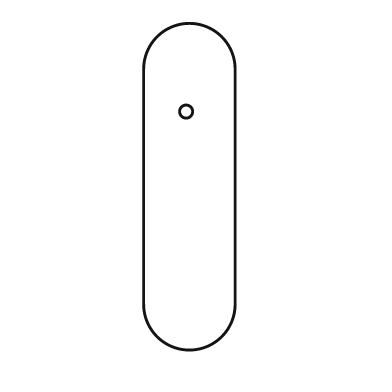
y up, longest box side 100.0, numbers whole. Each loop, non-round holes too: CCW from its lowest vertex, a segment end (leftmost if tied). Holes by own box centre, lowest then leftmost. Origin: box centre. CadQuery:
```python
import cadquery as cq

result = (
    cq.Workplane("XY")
    .moveTo(-14.0, -36.0)
    .threePointArc((0.0, -50.0), (14.0, -36.0))
    .lineTo(14.0, 36.0)
    .threePointArc((0.0, 50.0), (-14.0, 36.0))
    .close()
    .moveTo(-1.0, 23.0)
    .circle(2.0)
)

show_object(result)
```